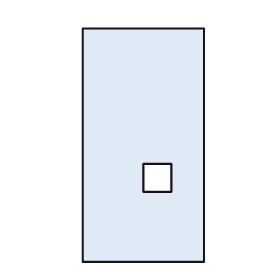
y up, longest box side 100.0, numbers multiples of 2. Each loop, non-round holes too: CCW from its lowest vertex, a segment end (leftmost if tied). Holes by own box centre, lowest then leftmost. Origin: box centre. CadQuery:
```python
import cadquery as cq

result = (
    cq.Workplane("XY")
    .moveTo(-26.0, -50.0)
    .lineTo(26.0, -50.0)
    .lineTo(26.0, 50.0)
    .lineTo(-26.0, 50.0)
    .close()
    .moveTo(0.0, -20.0)
    .lineTo(12.0, -20.0)
    .lineTo(12.0, -8.0)
    .lineTo(0.0, -8.0)
    .close()
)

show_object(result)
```